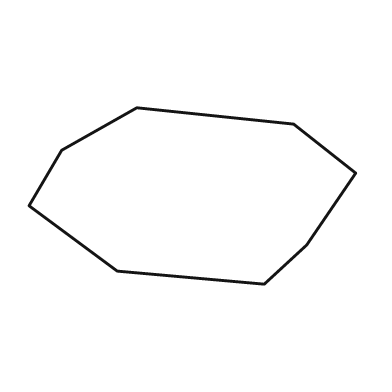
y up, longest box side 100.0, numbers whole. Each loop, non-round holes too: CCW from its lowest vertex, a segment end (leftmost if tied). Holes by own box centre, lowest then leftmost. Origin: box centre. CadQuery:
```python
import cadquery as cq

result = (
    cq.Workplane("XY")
    .moveTo(22.0, -27.0)
    .lineTo(35.0, -15.0)
    .lineTo(50.0, 7.0)
    .lineTo(31.0, 22.0)
    .lineTo(-17.0, 27.0)
    .lineTo(-40.0, 14.0)
    .lineTo(-50.0, -3.0)
    .lineTo(-23.0, -23.0)
    .close()
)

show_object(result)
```